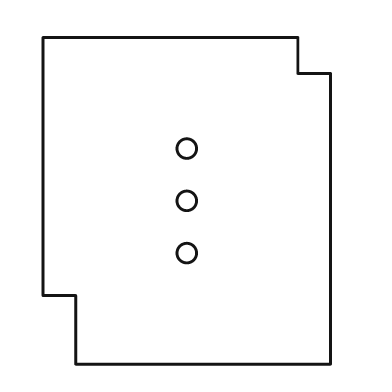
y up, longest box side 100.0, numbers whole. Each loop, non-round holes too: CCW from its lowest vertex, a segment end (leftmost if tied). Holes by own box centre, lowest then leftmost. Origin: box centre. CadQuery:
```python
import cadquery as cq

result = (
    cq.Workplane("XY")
    .moveTo(-34.0, -50.0)
    .lineTo(44.0, -50.0)
    .lineTo(44.0, 39.0)
    .lineTo(34.0, 39.0)
    .lineTo(34.0, 50.0)
    .lineTo(-44.0, 50.0)
    .lineTo(-44.0, -29.0)
    .lineTo(-34.0, -29.0)
    .close()
    .moveTo(0.0, -16.0)
    .circle(3.0)
    .moveTo(0.0, 0.0)
    .circle(3.0)
    .moveTo(0.0, 16.0)
    .circle(3.0)
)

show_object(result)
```